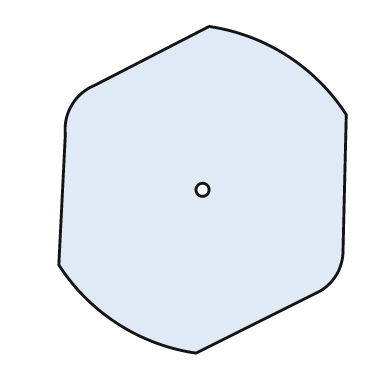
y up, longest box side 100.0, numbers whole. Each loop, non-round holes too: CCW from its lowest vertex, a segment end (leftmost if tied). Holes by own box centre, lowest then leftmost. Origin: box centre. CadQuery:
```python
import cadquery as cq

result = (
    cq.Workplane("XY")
    .moveTo(-2.0, -50.0)
    .lineTo(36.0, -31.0)
    .threePointArc((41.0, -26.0), (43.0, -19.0))
    .lineTo(44.0, 23.0)
    .threePointArc((26.0, 41.0), (2.0, 50.0))
    .lineTo(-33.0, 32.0)
    .threePointArc((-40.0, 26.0), (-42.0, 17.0))
    .lineTo(-44.0, -23.0)
    .threePointArc((-26.0, -41.0), (-2.0, -50.0))
    .close()
    .moveTo(0.0, 0.0)
    .circle(2.0)
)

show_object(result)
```